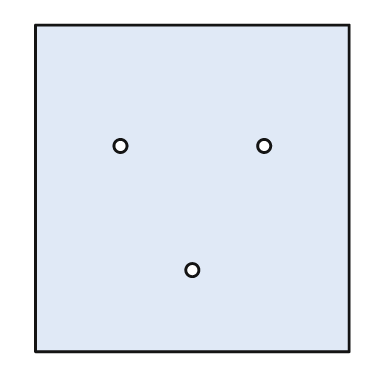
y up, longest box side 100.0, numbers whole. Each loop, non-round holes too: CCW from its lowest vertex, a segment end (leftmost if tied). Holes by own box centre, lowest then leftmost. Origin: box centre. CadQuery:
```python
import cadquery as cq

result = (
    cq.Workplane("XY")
    .moveTo(-48.0, -50.0)
    .lineTo(48.0, -50.0)
    .lineTo(48.0, 50.0)
    .lineTo(-48.0, 50.0)
    .close()
    .moveTo(0.0, -25.0)
    .circle(2.0)
    .moveTo(-22.0, 13.0)
    .circle(2.0)
    .moveTo(22.0, 13.0)
    .circle(2.0)
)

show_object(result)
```